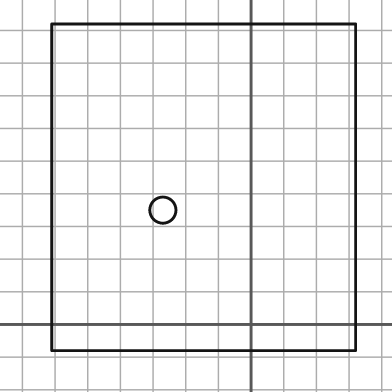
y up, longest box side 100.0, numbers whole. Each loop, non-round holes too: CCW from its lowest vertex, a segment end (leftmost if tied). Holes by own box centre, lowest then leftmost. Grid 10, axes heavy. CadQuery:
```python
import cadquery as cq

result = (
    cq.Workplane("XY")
    .moveTo(-61.0, -8.0)
    .lineTo(32.0, -8.0)
    .lineTo(32.0, 92.0)
    .lineTo(-61.0, 92.0)
    .close()
    .moveTo(-27.0, 35.0)
    .circle(4.0)
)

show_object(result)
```